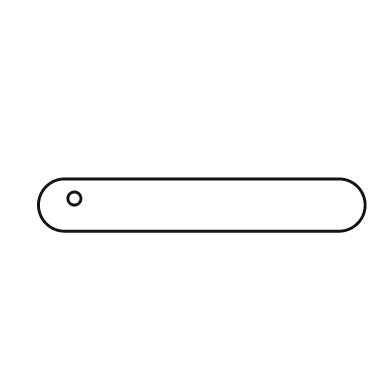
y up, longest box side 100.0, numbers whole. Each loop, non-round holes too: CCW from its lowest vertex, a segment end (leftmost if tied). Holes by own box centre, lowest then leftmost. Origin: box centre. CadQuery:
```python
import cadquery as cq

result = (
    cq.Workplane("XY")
    .moveTo(-42.0, -8.0)
    .lineTo(42.0, -8.0)
    .threePointArc((50.0, 0.0), (42.0, 8.0))
    .lineTo(-42.0, 8.0)
    .threePointArc((-50.0, 0.0), (-42.0, -8.0))
    .close()
    .moveTo(-39.0, 2.0)
    .circle(2.0)
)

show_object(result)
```